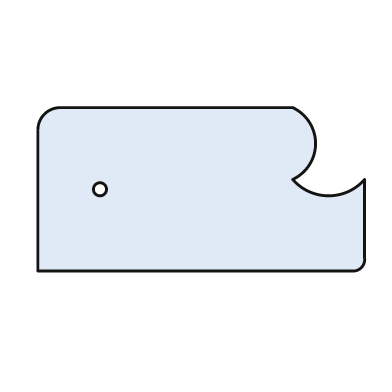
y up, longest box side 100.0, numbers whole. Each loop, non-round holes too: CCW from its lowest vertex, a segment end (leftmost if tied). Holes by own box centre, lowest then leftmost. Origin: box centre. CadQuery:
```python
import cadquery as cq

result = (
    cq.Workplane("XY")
    .moveTo(-50.0, -25.0)
    .lineTo(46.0, -25.0)
    .threePointArc((49.0, -24.0), (50.0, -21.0))
    .lineTo(50.0, 3.0)
    .threePointArc((39.0, -2.0), (28.0, 3.0))
    .threePointArc((35.0, 14.0), (28.0, 25.0))
    .lineTo(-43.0, 25.0)
    .threePointArc((-48.0, 23.0), (-50.0, 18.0))
    .close()
    .moveTo(-31.0, 0.0)
    .circle(2.0)
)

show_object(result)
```